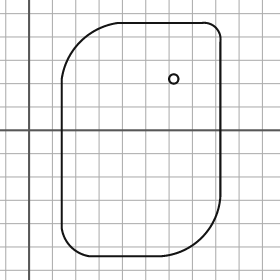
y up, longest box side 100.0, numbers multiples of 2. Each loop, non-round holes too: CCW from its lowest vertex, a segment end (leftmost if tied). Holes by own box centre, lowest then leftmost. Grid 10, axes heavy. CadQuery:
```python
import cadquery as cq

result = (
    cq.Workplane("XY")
    .moveTo(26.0, -54.0)
    .lineTo(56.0, -54.0)
    .threePointArc((74.0, -46.0), (82.0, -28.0))
    .lineTo(82.0, 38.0)
    .threePointArc((80.0, 44.0), (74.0, 46.0))
    .lineTo(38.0, 46.0)
    .threePointArc((22.0, 38.0), (14.0, 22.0))
    .lineTo(14.0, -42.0)
    .threePointArc((18.0, -50.0), (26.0, -54.0))
    .close()
    .moveTo(62.0, 22.0)
    .circle(2.0)
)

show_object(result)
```